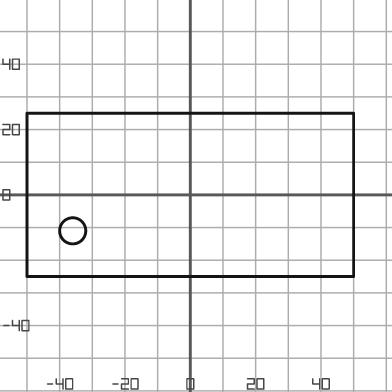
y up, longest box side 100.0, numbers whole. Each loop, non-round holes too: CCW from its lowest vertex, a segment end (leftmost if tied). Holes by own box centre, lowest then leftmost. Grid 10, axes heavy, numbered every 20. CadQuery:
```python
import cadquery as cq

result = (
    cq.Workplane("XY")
    .moveTo(-50.0, -25.0)
    .lineTo(50.0, -25.0)
    .lineTo(50.0, 25.0)
    .lineTo(-50.0, 25.0)
    .close()
    .moveTo(-36.0, -11.0)
    .circle(4.0)
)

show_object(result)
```